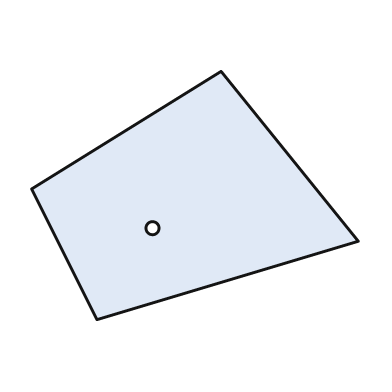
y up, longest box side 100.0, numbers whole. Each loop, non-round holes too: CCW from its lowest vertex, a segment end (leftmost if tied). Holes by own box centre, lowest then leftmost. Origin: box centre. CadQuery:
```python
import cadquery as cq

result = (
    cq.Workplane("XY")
    .moveTo(-30.0, -38.0)
    .lineTo(50.0, -14.0)
    .lineTo(8.0, 38.0)
    .lineTo(-50.0, 2.0)
    .close()
    .moveTo(-13.0, -10.0)
    .circle(2.0)
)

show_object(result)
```